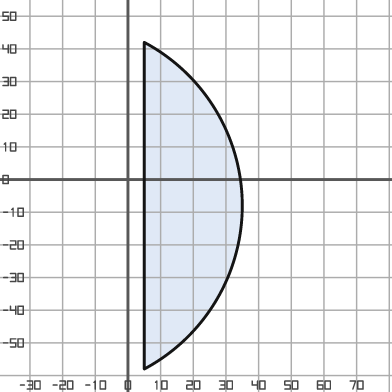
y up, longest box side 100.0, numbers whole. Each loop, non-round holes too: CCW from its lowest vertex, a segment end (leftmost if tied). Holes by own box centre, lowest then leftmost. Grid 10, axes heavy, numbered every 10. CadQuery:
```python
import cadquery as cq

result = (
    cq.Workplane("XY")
    .moveTo(5.0, -58.0)
    .threePointArc((35.0, -8.0), (5.0, 42.0))
    .close()
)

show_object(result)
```